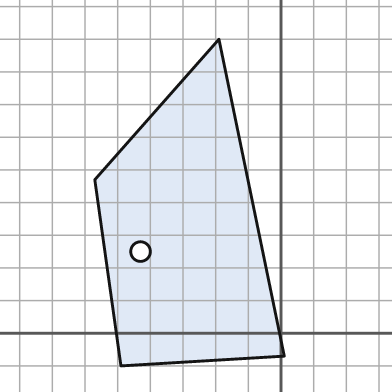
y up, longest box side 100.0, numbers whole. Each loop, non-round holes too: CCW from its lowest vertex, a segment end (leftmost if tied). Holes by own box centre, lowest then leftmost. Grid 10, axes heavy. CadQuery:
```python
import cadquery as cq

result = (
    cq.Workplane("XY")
    .moveTo(-49.0, -10.0)
    .lineTo(1.0, -7.0)
    .lineTo(-19.0, 90.0)
    .lineTo(-57.0, 47.0)
    .close()
    .moveTo(-43.0, 25.0)
    .circle(3.0)
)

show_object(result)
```